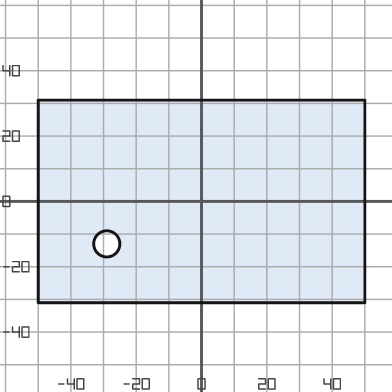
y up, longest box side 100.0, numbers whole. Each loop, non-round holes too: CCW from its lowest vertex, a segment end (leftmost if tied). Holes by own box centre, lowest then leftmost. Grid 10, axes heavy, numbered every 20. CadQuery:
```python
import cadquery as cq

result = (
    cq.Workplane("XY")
    .moveTo(-50.0, -31.0)
    .lineTo(50.0, -31.0)
    .lineTo(50.0, 31.0)
    .lineTo(-50.0, 31.0)
    .close()
    .moveTo(-29.0, -13.0)
    .circle(4.0)
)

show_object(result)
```